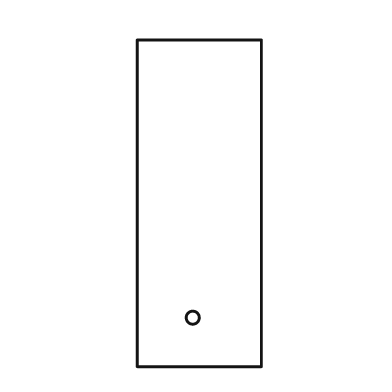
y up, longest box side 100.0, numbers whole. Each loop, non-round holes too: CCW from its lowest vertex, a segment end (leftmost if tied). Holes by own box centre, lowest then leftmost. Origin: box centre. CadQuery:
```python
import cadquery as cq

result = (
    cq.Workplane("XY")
    .moveTo(-19.0, -50.0)
    .lineTo(19.0, -50.0)
    .lineTo(19.0, 50.0)
    .lineTo(-19.0, 50.0)
    .close()
    .moveTo(-2.0, -35.0)
    .circle(2.0)
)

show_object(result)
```